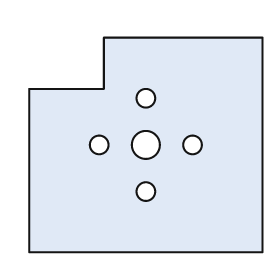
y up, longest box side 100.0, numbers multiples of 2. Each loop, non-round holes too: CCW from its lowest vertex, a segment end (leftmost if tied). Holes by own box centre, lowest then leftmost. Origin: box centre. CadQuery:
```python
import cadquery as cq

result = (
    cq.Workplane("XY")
    .moveTo(-50.0, -46.0)
    .lineTo(50.0, -46.0)
    .lineTo(50.0, 46.0)
    .lineTo(-18.0, 46.0)
    .lineTo(-18.0, 24.0)
    .lineTo(-50.0, 24.0)
    .close()
    .moveTo(0.0, -20.0)
    .circle(4.0)
    .moveTo(-20.0, 0.0)
    .circle(4.0)
    .moveTo(0.0, 0.0)
    .circle(6.0)
    .moveTo(20.0, 0.0)
    .circle(4.0)
    .moveTo(0.0, 20.0)
    .circle(4.0)
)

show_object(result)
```